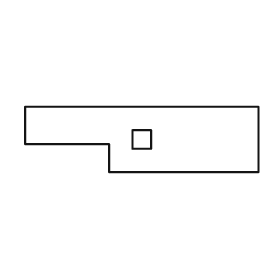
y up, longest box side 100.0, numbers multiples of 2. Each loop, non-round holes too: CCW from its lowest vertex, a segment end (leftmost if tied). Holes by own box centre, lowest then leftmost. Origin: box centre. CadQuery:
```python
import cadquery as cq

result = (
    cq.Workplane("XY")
    .moveTo(-14.0, -14.0)
    .lineTo(50.0, -14.0)
    .lineTo(50.0, 14.0)
    .lineTo(-50.0, 14.0)
    .lineTo(-50.0, -2.0)
    .lineTo(-14.0, -2.0)
    .close()
    .moveTo(-4.0, -4.0)
    .lineTo(4.0, -4.0)
    .lineTo(4.0, 4.0)
    .lineTo(-4.0, 4.0)
    .close()
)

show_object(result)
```